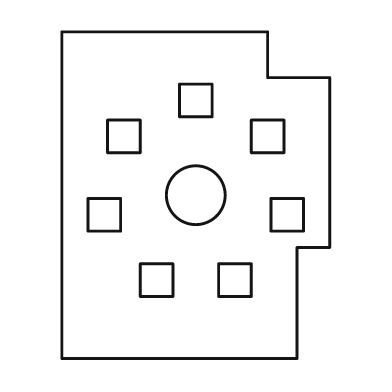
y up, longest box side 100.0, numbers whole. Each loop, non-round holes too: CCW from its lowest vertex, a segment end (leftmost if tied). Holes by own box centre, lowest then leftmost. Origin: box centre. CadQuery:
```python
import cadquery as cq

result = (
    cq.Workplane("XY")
    .moveTo(-41.0, -50.0)
    .lineTo(31.0, -50.0)
    .lineTo(31.0, -16.0)
    .lineTo(41.0, -16.0)
    .lineTo(41.0, 36.0)
    .lineTo(22.0, 36.0)
    .lineTo(22.0, 50.0)
    .lineTo(-41.0, 50.0)
    .close()
    .moveTo(-17.0, -31.0)
    .lineTo(-7.0, -31.0)
    .lineTo(-7.0, -21.0)
    .lineTo(-17.0, -21.0)
    .close()
    .moveTo(7.0, -31.0)
    .lineTo(17.0, -31.0)
    .lineTo(17.0, -21.0)
    .lineTo(7.0, -21.0)
    .close()
    .moveTo(-33.0, -11.0)
    .lineTo(-23.0, -11.0)
    .lineTo(-23.0, -1.0)
    .lineTo(-33.0, -1.0)
    .close()
    .moveTo(23.0, -11.0)
    .lineTo(33.0, -11.0)
    .lineTo(33.0, -1.0)
    .lineTo(23.0, -1.0)
    .close()
    .moveTo(0.0, 0.0)
    .circle(9.0)
    .moveTo(-27.0, 13.0)
    .lineTo(-17.0, 13.0)
    .lineTo(-17.0, 23.0)
    .lineTo(-27.0, 23.0)
    .close()
    .moveTo(17.0, 13.0)
    .lineTo(27.0, 13.0)
    .lineTo(27.0, 23.0)
    .lineTo(17.0, 23.0)
    .close()
    .moveTo(-5.0, 24.0)
    .lineTo(5.0, 24.0)
    .lineTo(5.0, 34.0)
    .lineTo(-5.0, 34.0)
    .close()
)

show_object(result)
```